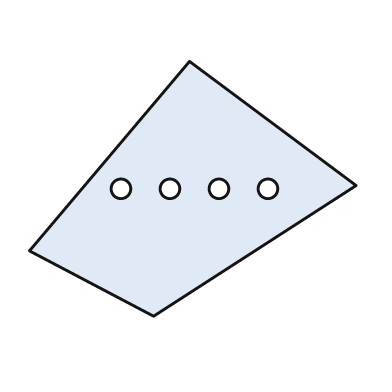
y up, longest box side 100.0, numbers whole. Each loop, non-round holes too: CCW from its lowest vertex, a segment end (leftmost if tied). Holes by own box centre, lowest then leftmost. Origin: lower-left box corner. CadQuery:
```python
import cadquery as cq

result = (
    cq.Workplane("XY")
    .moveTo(38.0, 0.0)
    .lineTo(100.0, 40.0)
    .lineTo(49.0, 78.0)
    .lineTo(0.0, 20.0)
    .close()
    .moveTo(28.0, 39.0)
    .circle(3.0)
    .moveTo(43.0, 39.0)
    .circle(3.0)
    .moveTo(58.0, 39.0)
    .circle(3.0)
    .moveTo(73.0, 39.0)
    .circle(3.0)
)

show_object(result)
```